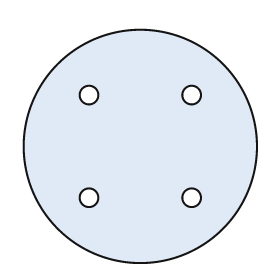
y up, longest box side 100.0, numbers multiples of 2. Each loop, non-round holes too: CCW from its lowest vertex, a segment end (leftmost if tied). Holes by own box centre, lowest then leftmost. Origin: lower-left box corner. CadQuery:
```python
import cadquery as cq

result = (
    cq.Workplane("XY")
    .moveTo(50.0, 50.0)
    .circle(50.0)
    .moveTo(28.0, 28.0)
    .circle(4.0)
    .moveTo(72.0, 28.0)
    .circle(4.0)
    .moveTo(28.0, 72.0)
    .circle(4.0)
    .moveTo(72.0, 72.0)
    .circle(4.0)
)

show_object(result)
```